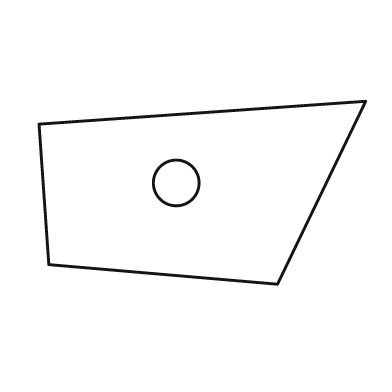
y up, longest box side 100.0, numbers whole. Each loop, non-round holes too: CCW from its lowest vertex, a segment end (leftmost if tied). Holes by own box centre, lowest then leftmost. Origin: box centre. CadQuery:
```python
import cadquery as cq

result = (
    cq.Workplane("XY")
    .moveTo(23.0, -28.0)
    .lineTo(50.0, 28.0)
    .lineTo(-50.0, 21.0)
    .lineTo(-47.0, -22.0)
    .close()
    .moveTo(-8.0, 3.0)
    .circle(7.0)
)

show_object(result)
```